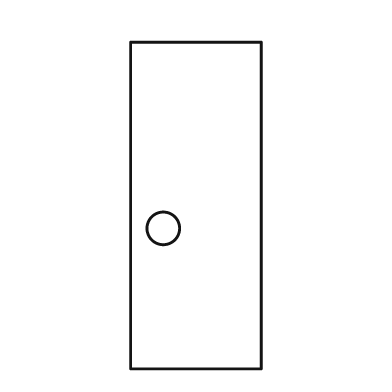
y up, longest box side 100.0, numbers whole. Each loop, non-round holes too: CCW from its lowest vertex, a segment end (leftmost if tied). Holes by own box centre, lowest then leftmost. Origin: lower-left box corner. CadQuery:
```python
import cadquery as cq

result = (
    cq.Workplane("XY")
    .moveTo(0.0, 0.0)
    .lineTo(40.0, 0.0)
    .lineTo(40.0, 100.0)
    .lineTo(0.0, 100.0)
    .close()
    .moveTo(10.0, 43.0)
    .circle(5.0)
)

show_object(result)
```